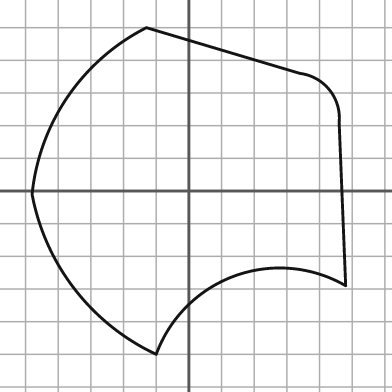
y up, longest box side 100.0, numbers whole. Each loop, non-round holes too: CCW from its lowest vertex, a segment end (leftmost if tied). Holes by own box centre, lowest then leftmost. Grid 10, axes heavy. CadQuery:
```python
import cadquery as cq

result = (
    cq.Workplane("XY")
    .moveTo(-10.0, -50.0)
    .threePointArc((14.0, -26.0), (48.0, -29.0))
    .lineTo(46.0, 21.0)
    .threePointArc((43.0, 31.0), (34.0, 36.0))
    .lineTo(-13.0, 50.0)
    .threePointArc((-37.0, 29.0), (-48.0, -1.0))
    .threePointArc((-35.0, -30.0), (-10.0, -50.0))
    .close()
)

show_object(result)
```